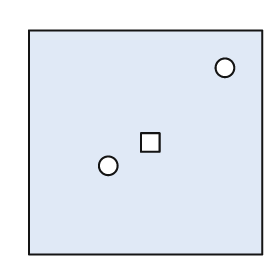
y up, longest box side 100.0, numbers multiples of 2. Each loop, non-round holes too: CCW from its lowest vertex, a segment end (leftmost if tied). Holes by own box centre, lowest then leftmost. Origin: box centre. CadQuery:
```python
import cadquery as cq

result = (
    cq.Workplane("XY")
    .moveTo(-50.0, -48.0)
    .lineTo(50.0, -48.0)
    .lineTo(50.0, 48.0)
    .lineTo(-50.0, 48.0)
    .close()
    .moveTo(-16.0, -10.0)
    .circle(4.0)
    .moveTo(-2.0, -4.0)
    .lineTo(6.0, -4.0)
    .lineTo(6.0, 4.0)
    .lineTo(-2.0, 4.0)
    .close()
    .moveTo(34.0, 32.0)
    .circle(4.0)
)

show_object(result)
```